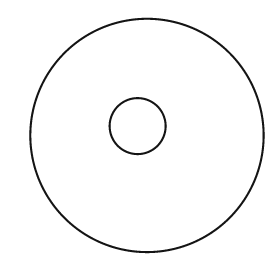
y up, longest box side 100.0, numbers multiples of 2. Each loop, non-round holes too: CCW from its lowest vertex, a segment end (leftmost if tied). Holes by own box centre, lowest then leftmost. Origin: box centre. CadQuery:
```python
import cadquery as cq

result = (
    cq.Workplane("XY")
    .moveTo(0.0, 0.0)
    .circle(50.0)
    .moveTo(-4.0, 4.0)
    .circle(12.0)
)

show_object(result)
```